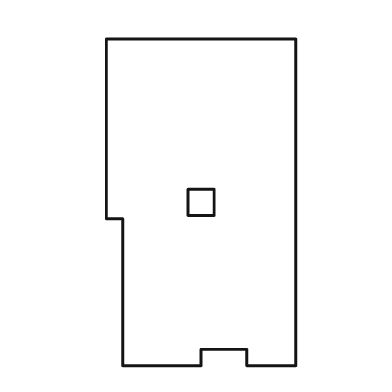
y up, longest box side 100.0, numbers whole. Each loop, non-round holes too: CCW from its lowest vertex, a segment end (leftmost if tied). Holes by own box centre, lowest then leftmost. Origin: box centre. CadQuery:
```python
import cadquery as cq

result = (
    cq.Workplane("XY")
    .moveTo(-24.0, -50.0)
    .lineTo(0.0, -50.0)
    .lineTo(0.0, -45.0)
    .lineTo(14.0, -45.0)
    .lineTo(14.0, -50.0)
    .lineTo(29.0, -50.0)
    .lineTo(29.0, 50.0)
    .lineTo(-29.0, 50.0)
    .lineTo(-29.0, -5.0)
    .lineTo(-24.0, -5.0)
    .close()
    .moveTo(-4.0, -4.0)
    .lineTo(4.0, -4.0)
    .lineTo(4.0, 4.0)
    .lineTo(-4.0, 4.0)
    .close()
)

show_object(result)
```